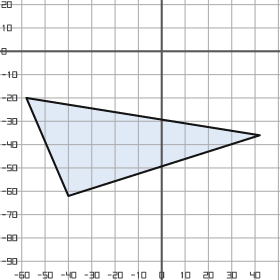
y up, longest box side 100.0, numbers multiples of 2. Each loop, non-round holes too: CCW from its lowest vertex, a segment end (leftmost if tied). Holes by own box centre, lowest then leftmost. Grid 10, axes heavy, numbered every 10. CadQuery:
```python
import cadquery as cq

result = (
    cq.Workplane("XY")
    .moveTo(-40.0, -62.0)
    .lineTo(42.0, -36.0)
    .lineTo(-58.0, -20.0)
    .close()
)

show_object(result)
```